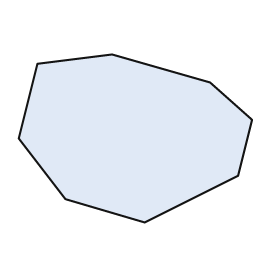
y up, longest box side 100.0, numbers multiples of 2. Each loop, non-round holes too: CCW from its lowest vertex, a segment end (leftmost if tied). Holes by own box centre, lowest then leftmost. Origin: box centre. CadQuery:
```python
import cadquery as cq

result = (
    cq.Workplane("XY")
    .moveTo(4.0, -36.0)
    .lineTo(44.0, -16.0)
    .lineTo(50.0, 8.0)
    .lineTo(32.0, 24.0)
    .lineTo(-10.0, 36.0)
    .lineTo(-42.0, 32.0)
    .lineTo(-50.0, 0.0)
    .lineTo(-30.0, -26.0)
    .close()
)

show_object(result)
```